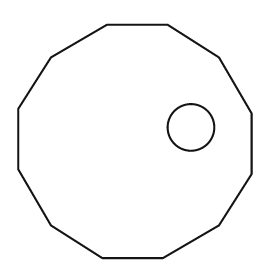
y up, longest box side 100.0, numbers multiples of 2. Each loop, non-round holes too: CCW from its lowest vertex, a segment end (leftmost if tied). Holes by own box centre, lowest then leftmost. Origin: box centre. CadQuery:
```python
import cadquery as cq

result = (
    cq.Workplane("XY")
    .moveTo(-14.0, -50.0)
    .lineTo(12.0, -50.0)
    .lineTo(36.0, -36.0)
    .lineTo(50.0, -14.0)
    .lineTo(50.0, 12.0)
    .lineTo(36.0, 36.0)
    .lineTo(14.0, 50.0)
    .lineTo(-12.0, 50.0)
    .lineTo(-36.0, 36.0)
    .lineTo(-50.0, 14.0)
    .lineTo(-50.0, -12.0)
    .lineTo(-36.0, -36.0)
    .close()
    .moveTo(24.0, 6.0)
    .circle(10.0)
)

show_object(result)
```